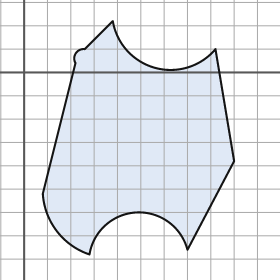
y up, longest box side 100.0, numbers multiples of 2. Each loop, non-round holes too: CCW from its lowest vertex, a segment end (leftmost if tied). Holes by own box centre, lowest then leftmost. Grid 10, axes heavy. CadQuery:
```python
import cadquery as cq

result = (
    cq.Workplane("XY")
    .moveTo(28.0, -78.0)
    .threePointArc((48.0, -60.0), (70.0, -76.0))
    .lineTo(90.0, -38.0)
    .lineTo(82.0, 10.0)
    .threePointArc((56.0, 2.0), (38.0, 22.0))
    .lineTo(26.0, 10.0)
    .threePointArc((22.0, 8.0), (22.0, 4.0))
    .lineTo(8.0, -52.0)
    .threePointArc((14.0, -68.0), (28.0, -78.0))
    .close()
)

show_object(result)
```